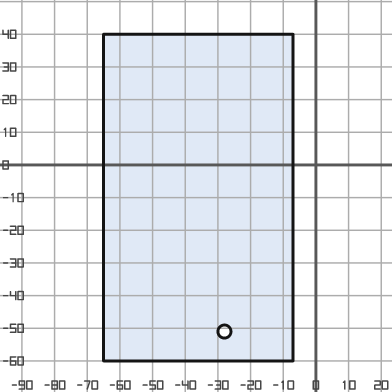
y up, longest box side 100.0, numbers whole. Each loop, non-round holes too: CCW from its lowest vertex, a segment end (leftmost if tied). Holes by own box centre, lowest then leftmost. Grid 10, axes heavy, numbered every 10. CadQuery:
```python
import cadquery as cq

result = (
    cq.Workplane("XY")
    .moveTo(-65.0, -60.0)
    .lineTo(-7.0, -60.0)
    .lineTo(-7.0, 40.0)
    .lineTo(-65.0, 40.0)
    .close()
    .moveTo(-28.0, -51.0)
    .circle(2.0)
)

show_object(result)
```